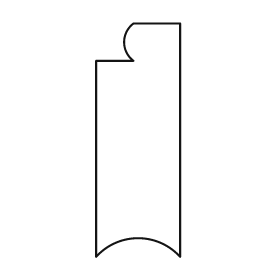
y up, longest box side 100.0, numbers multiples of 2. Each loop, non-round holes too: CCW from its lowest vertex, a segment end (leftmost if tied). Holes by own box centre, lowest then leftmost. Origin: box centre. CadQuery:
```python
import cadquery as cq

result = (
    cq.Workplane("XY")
    .moveTo(-18.0, -50.0)
    .threePointArc((0.0, -42.0), (18.0, -50.0))
    .lineTo(18.0, 50.0)
    .lineTo(-2.0, 50.0)
    .threePointArc((-6.0, 42.0), (-2.0, 34.0))
    .lineTo(-18.0, 34.0)
    .close()
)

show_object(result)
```